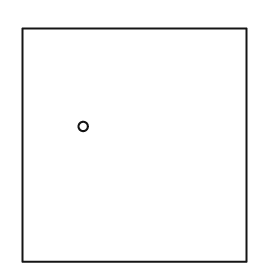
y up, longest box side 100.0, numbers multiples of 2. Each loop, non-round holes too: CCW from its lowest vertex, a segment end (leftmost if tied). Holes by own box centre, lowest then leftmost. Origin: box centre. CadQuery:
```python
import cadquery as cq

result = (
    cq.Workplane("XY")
    .moveTo(-48.0, -50.0)
    .lineTo(48.0, -50.0)
    .lineTo(48.0, 50.0)
    .lineTo(-48.0, 50.0)
    .close()
    .moveTo(-22.0, 8.0)
    .circle(2.0)
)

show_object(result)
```